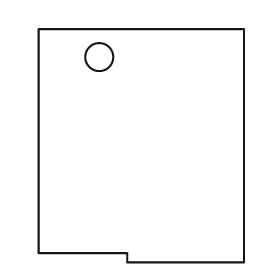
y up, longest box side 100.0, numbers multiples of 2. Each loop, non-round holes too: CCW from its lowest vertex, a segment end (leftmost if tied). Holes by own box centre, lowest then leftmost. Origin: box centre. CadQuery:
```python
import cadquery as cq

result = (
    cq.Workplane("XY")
    .moveTo(-6.0, -50.0)
    .lineTo(44.0, -50.0)
    .lineTo(44.0, 50.0)
    .lineTo(-44.0, 50.0)
    .lineTo(-44.0, -46.0)
    .lineTo(-6.0, -46.0)
    .close()
    .moveTo(-18.0, 38.0)
    .circle(6.0)
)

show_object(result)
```